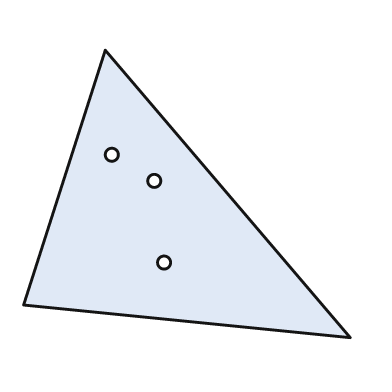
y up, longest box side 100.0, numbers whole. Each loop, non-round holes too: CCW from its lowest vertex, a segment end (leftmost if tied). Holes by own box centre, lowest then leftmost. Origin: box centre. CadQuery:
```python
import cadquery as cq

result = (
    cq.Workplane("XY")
    .moveTo(50.0, -44.0)
    .lineTo(-25.0, 44.0)
    .lineTo(-50.0, -34.0)
    .close()
    .moveTo(-7.0, -21.0)
    .circle(2.0)
    .moveTo(-10.0, 4.0)
    .circle(2.0)
    .moveTo(-23.0, 12.0)
    .circle(2.0)
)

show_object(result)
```